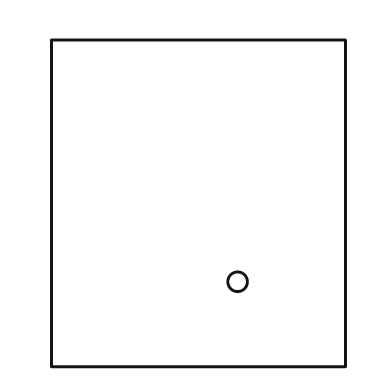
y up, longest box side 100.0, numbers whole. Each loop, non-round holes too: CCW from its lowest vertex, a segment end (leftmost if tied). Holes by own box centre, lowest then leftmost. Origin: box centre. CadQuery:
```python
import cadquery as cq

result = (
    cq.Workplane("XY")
    .moveTo(-45.0, -50.0)
    .lineTo(45.0, -50.0)
    .lineTo(45.0, 50.0)
    .lineTo(-45.0, 50.0)
    .close()
    .moveTo(12.0, -24.0)
    .circle(3.0)
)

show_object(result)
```